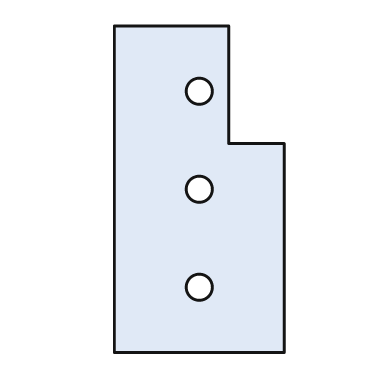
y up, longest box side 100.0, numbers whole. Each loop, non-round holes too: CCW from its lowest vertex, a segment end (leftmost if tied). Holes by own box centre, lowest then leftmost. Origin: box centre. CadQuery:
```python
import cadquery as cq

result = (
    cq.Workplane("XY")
    .moveTo(-26.0, -50.0)
    .lineTo(26.0, -50.0)
    .lineTo(26.0, 14.0)
    .lineTo(9.0, 14.0)
    .lineTo(9.0, 50.0)
    .lineTo(-26.0, 50.0)
    .close()
    .moveTo(0.0, -30.0)
    .circle(4.0)
    .moveTo(0.0, 0.0)
    .circle(4.0)
    .moveTo(0.0, 30.0)
    .circle(4.0)
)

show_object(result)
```